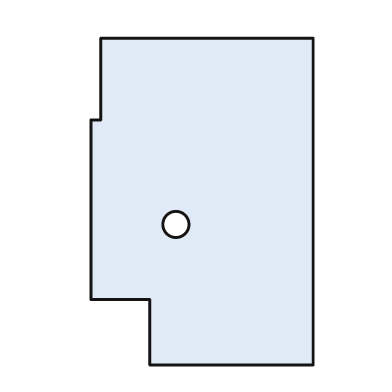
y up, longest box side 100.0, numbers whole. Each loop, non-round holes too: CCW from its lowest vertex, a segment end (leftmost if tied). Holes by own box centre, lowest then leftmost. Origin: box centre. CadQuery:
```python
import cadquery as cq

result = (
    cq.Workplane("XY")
    .moveTo(-16.0, -50.0)
    .lineTo(34.0, -50.0)
    .lineTo(34.0, 50.0)
    .lineTo(-31.0, 50.0)
    .lineTo(-31.0, 25.0)
    .lineTo(-34.0, 25.0)
    .lineTo(-34.0, -30.0)
    .lineTo(-16.0, -30.0)
    .close()
    .moveTo(-8.0, -7.0)
    .circle(4.0)
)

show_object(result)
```